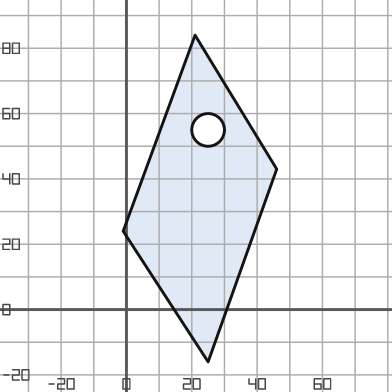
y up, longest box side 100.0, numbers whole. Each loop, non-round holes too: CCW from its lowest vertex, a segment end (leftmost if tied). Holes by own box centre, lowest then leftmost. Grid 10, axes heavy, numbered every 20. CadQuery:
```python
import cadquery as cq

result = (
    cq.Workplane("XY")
    .moveTo(25.0, -16.0)
    .lineTo(46.0, 43.0)
    .lineTo(21.0, 84.0)
    .lineTo(-1.0, 24.0)
    .close()
    .moveTo(25.0, 55.0)
    .circle(5.0)
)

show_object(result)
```